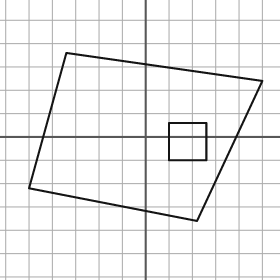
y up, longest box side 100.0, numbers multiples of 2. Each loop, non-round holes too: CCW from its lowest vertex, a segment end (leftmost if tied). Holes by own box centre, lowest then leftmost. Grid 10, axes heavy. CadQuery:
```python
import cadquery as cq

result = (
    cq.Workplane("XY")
    .moveTo(22.0, -36.0)
    .lineTo(50.0, 24.0)
    .lineTo(-34.0, 36.0)
    .lineTo(-50.0, -22.0)
    .close()
    .moveTo(10.0, -10.0)
    .lineTo(26.0, -10.0)
    .lineTo(26.0, 6.0)
    .lineTo(10.0, 6.0)
    .close()
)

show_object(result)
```